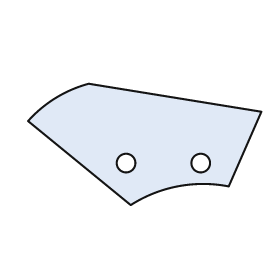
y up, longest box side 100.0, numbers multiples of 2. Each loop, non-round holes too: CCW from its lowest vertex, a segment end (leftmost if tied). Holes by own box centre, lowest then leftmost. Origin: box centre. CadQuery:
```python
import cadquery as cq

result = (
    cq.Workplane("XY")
    .moveTo(-6.0, -26.0)
    .threePointArc((14.0, -18.0), (36.0, -18.0))
    .lineTo(50.0, 14.0)
    .lineTo(-24.0, 26.0)
    .threePointArc((-38.0, 20.0), (-50.0, 10.0))
    .close()
    .moveTo(-8.0, -8.0)
    .circle(4.0)
    .moveTo(24.0, -8.0)
    .circle(4.0)
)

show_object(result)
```